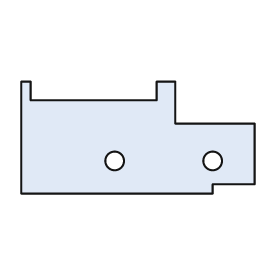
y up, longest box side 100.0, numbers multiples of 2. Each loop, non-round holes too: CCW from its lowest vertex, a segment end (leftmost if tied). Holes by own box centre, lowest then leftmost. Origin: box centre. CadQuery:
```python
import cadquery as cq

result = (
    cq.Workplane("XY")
    .moveTo(-50.0, -24.0)
    .lineTo(32.0, -24.0)
    .lineTo(32.0, -20.0)
    .lineTo(50.0, -20.0)
    .lineTo(50.0, 6.0)
    .lineTo(16.0, 6.0)
    .lineTo(16.0, 24.0)
    .lineTo(8.0, 24.0)
    .lineTo(8.0, 16.0)
    .lineTo(-46.0, 16.0)
    .lineTo(-46.0, 24.0)
    .lineTo(-50.0, 24.0)
    .close()
    .moveTo(-10.0, -10.0)
    .circle(4.0)
    .moveTo(32.0, -10.0)
    .circle(4.0)
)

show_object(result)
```